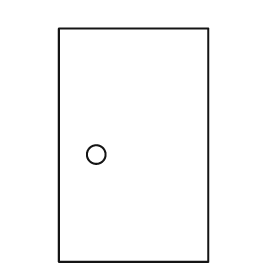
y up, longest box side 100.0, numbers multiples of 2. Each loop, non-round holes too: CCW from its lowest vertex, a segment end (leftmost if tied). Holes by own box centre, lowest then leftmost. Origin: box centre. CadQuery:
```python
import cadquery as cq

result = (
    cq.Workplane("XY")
    .moveTo(-32.0, -50.0)
    .lineTo(32.0, -50.0)
    .lineTo(32.0, 50.0)
    .lineTo(-32.0, 50.0)
    .close()
    .moveTo(-16.0, -4.0)
    .circle(4.0)
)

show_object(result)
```